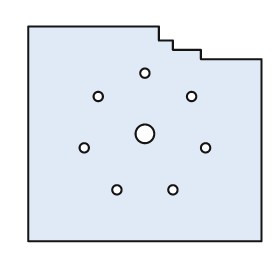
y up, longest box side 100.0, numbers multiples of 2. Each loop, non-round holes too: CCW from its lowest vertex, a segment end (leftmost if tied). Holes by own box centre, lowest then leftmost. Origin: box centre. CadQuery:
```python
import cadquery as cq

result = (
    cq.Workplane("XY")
    .moveTo(-50.0, -46.0)
    .lineTo(50.0, -46.0)
    .lineTo(50.0, 32.0)
    .lineTo(24.0, 32.0)
    .lineTo(24.0, 36.0)
    .lineTo(12.0, 36.0)
    .lineTo(12.0, 40.0)
    .lineTo(6.0, 40.0)
    .lineTo(6.0, 46.0)
    .lineTo(-50.0, 46.0)
    .close()
    .moveTo(-12.0, -24.0)
    .circle(2.0)
    .moveTo(12.0, -24.0)
    .circle(2.0)
    .moveTo(-26.0, -6.0)
    .circle(2.0)
    .moveTo(26.0, -6.0)
    .circle(2.0)
    .moveTo(0.0, 0.0)
    .circle(4.0)
    .moveTo(-20.0, 16.0)
    .circle(2.0)
    .moveTo(20.0, 16.0)
    .circle(2.0)
    .moveTo(0.0, 26.0)
    .circle(2.0)
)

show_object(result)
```